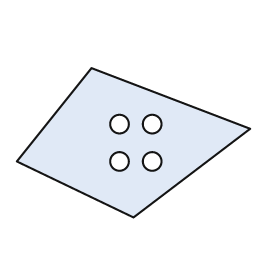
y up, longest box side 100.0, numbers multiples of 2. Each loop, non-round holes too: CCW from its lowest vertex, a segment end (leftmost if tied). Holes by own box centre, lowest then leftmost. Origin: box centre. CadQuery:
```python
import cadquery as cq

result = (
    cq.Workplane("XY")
    .moveTo(0.0, -32.0)
    .lineTo(50.0, 6.0)
    .lineTo(-18.0, 32.0)
    .lineTo(-50.0, -8.0)
    .close()
    .moveTo(-6.0, -8.0)
    .circle(4.0)
    .moveTo(8.0, -8.0)
    .circle(4.0)
    .moveTo(-6.0, 8.0)
    .circle(4.0)
    .moveTo(8.0, 8.0)
    .circle(4.0)
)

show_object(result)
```